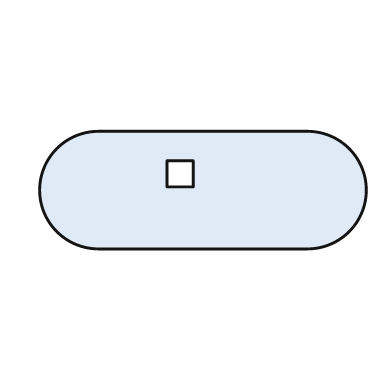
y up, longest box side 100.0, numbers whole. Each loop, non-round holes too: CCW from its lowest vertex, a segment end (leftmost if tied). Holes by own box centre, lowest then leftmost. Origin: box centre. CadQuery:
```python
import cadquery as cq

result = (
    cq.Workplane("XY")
    .moveTo(-32.0, -18.0)
    .lineTo(32.0, -18.0)
    .threePointArc((50.0, 0.0), (32.0, 18.0))
    .lineTo(-32.0, 18.0)
    .threePointArc((-50.0, 0.0), (-32.0, -18.0))
    .close()
    .moveTo(-11.0, 1.0)
    .lineTo(-3.0, 1.0)
    .lineTo(-3.0, 9.0)
    .lineTo(-11.0, 9.0)
    .close()
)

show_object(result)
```